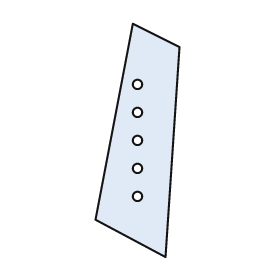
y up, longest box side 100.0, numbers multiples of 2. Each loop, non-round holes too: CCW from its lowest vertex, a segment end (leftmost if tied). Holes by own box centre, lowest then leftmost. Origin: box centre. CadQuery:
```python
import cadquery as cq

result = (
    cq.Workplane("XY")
    .moveTo(12.0, -50.0)
    .lineTo(18.0, 40.0)
    .lineTo(-2.0, 50.0)
    .lineTo(-18.0, -34.0)
    .close()
    .moveTo(0.0, -24.0)
    .circle(2.0)
    .moveTo(0.0, -12.0)
    .circle(2.0)
    .moveTo(0.0, 0.0)
    .circle(2.0)
    .moveTo(0.0, 12.0)
    .circle(2.0)
    .moveTo(0.0, 24.0)
    .circle(2.0)
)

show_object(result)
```